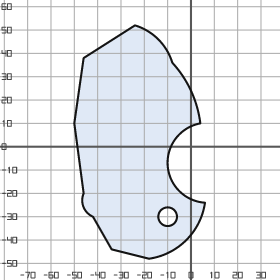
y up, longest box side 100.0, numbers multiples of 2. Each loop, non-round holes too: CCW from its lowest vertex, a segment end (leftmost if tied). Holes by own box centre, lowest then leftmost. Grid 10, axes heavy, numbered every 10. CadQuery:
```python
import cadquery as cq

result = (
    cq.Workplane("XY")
    .moveTo(-18.0, -48.0)
    .threePointArc((-2.0, -40.0), (6.0, -24.0))
    .threePointArc((-10.0, -8.0), (4.0, 10.0))
    .threePointArc((0.0, 24.0), (-8.0, 36.0))
    .threePointArc((-14.0, 46.0), (-24.0, 52.0))
    .lineTo(-46.0, 38.0)
    .lineTo(-50.0, 10.0)
    .lineTo(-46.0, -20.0)
    .threePointArc((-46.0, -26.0), (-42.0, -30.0))
    .lineTo(-34.0, -44.0)
    .close()
    .moveTo(-10.0, -30.0)
    .circle(4.0)
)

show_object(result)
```